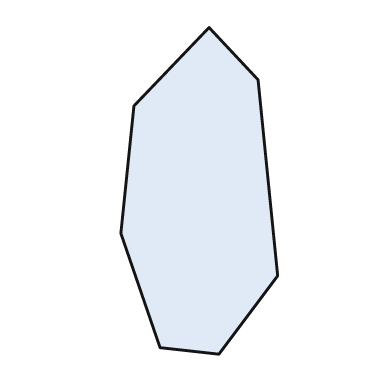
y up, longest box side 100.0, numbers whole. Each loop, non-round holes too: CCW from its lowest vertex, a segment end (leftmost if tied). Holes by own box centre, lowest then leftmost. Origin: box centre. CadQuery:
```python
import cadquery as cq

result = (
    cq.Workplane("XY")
    .moveTo(6.0, -50.0)
    .lineTo(24.0, -26.0)
    .lineTo(18.0, 34.0)
    .lineTo(3.0, 50.0)
    .lineTo(-20.0, 26.0)
    .lineTo(-24.0, -13.0)
    .lineTo(-12.0, -48.0)
    .close()
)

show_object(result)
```